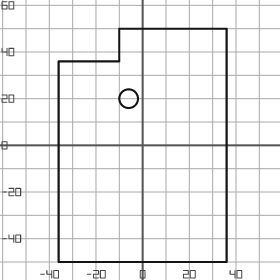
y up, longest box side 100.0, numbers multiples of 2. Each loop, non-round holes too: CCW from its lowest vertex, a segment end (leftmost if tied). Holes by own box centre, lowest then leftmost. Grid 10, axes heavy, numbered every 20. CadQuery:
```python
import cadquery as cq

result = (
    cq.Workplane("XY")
    .moveTo(-36.0, -50.0)
    .lineTo(36.0, -50.0)
    .lineTo(36.0, 50.0)
    .lineTo(-10.0, 50.0)
    .lineTo(-10.0, 36.0)
    .lineTo(-36.0, 36.0)
    .close()
    .moveTo(-6.0, 20.0)
    .circle(4.0)
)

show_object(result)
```